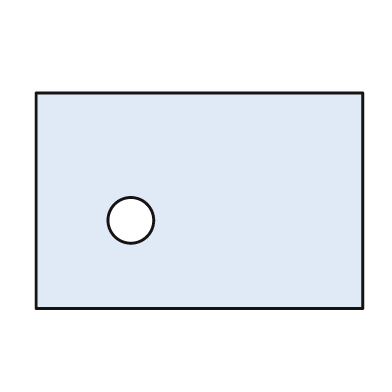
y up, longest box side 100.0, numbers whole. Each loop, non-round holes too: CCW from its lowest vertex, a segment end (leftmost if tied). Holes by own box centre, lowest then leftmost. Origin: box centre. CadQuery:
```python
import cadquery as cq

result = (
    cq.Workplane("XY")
    .moveTo(-50.0, -33.0)
    .lineTo(50.0, -33.0)
    .lineTo(50.0, 33.0)
    .lineTo(-50.0, 33.0)
    .close()
    .moveTo(-21.0, -6.0)
    .circle(7.0)
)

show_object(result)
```